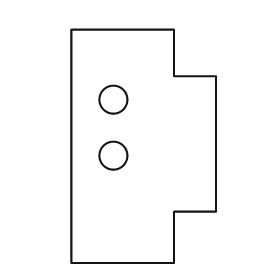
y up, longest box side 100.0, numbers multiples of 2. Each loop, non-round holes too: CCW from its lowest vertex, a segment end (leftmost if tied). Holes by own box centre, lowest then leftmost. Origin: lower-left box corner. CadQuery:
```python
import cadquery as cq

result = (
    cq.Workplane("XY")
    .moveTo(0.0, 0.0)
    .lineTo(44.0, 0.0)
    .lineTo(44.0, 22.0)
    .lineTo(62.0, 22.0)
    .lineTo(62.0, 80.0)
    .lineTo(44.0, 80.0)
    .lineTo(44.0, 100.0)
    .lineTo(0.0, 100.0)
    .close()
    .moveTo(18.0, 46.0)
    .circle(6.0)
    .moveTo(18.0, 70.0)
    .circle(6.0)
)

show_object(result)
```